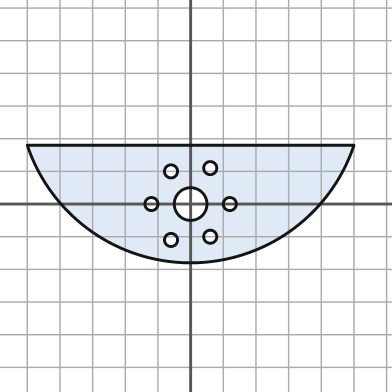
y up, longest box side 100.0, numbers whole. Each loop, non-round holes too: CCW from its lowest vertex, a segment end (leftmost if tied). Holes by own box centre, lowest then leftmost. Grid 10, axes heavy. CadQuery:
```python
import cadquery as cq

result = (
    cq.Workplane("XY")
    .moveTo(-50.0, 18.0)
    .threePointArc((0.0, -18.0), (50.0, 18.0))
    .close()
    .moveTo(-6.0, -11.0)
    .circle(2.0)
    .moveTo(6.0, -10.0)
    .circle(2.0)
    .moveTo(-12.0, 0.0)
    .circle(2.0)
    .moveTo(0.0, 0.0)
    .circle(5.0)
    .moveTo(12.0, 0.0)
    .circle(2.0)
    .moveTo(-6.0, 10.0)
    .circle(2.0)
    .moveTo(6.0, 11.0)
    .circle(2.0)
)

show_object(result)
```